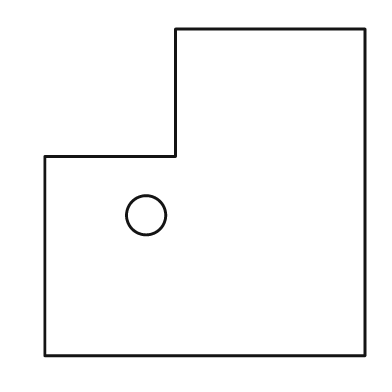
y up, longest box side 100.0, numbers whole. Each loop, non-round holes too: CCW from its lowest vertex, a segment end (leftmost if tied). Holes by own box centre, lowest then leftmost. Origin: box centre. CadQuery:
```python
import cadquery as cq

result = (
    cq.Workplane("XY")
    .moveTo(-49.0, -50.0)
    .lineTo(49.0, -50.0)
    .lineTo(49.0, 50.0)
    .lineTo(-9.0, 50.0)
    .lineTo(-9.0, 11.0)
    .lineTo(-49.0, 11.0)
    .close()
    .moveTo(-18.0, -7.0)
    .circle(6.0)
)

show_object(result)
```